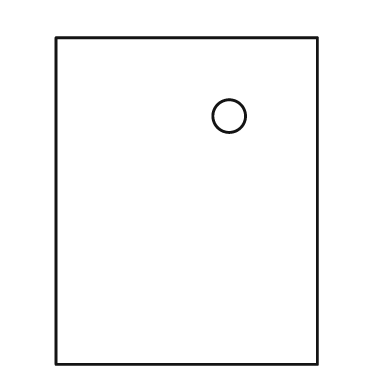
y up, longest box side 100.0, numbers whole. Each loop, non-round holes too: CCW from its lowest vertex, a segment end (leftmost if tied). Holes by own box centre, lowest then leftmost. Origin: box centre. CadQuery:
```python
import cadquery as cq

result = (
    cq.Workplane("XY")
    .moveTo(-40.0, -50.0)
    .lineTo(40.0, -50.0)
    .lineTo(40.0, 50.0)
    .lineTo(-40.0, 50.0)
    .close()
    .moveTo(13.0, 26.0)
    .circle(5.0)
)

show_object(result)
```